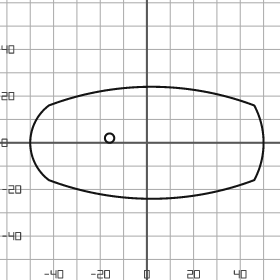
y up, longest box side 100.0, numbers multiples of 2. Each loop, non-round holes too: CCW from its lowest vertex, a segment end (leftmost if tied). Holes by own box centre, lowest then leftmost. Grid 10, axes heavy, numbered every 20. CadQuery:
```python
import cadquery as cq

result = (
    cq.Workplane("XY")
    .moveTo(-42.0, -16.0)
    .threePointArc((2.0, -24.0), (46.0, -16.0))
    .threePointArc((50.0, 0.0), (46.0, 16.0))
    .threePointArc((2.0, 24.0), (-42.0, 16.0))
    .threePointArc((-50.0, 0.0), (-42.0, -16.0))
    .close()
    .moveTo(-16.0, 2.0)
    .circle(2.0)
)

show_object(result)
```